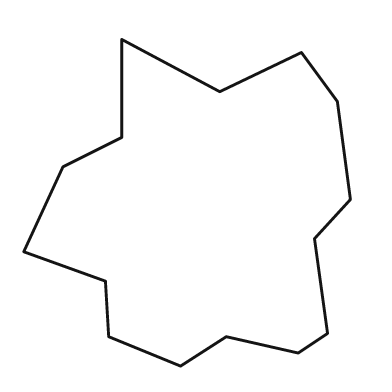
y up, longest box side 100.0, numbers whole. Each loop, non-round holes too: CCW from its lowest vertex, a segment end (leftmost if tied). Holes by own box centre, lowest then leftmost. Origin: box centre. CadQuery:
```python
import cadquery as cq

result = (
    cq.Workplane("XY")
    .moveTo(-2.0, -50.0)
    .lineTo(12.0, -41.0)
    .lineTo(34.0, -46.0)
    .lineTo(43.0, -40.0)
    .lineTo(39.0, -11.0)
    .lineTo(50.0, 1.0)
    .lineTo(46.0, 31.0)
    .lineTo(35.0, 46.0)
    .lineTo(10.0, 34.0)
    .lineTo(-20.0, 50.0)
    .lineTo(-20.0, 20.0)
    .lineTo(-38.0, 11.0)
    .lineTo(-50.0, -15.0)
    .lineTo(-25.0, -24.0)
    .lineTo(-24.0, -41.0)
    .close()
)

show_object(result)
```